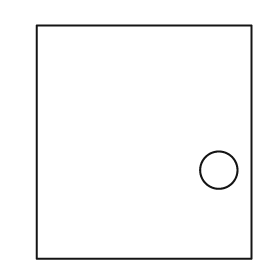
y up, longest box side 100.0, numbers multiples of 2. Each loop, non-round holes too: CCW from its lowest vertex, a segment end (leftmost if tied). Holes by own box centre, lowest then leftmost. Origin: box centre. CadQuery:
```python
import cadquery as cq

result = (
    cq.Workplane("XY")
    .moveTo(-46.0, -50.0)
    .lineTo(46.0, -50.0)
    .lineTo(46.0, 50.0)
    .lineTo(-46.0, 50.0)
    .close()
    .moveTo(32.0, -12.0)
    .circle(8.0)
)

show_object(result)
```